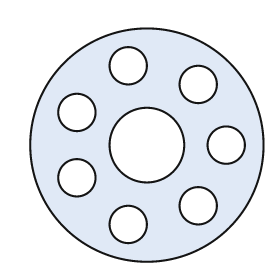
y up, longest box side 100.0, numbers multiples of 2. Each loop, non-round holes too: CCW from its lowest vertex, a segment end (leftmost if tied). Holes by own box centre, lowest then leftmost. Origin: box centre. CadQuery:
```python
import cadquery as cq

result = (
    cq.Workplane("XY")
    .moveTo(0.0, 0.0)
    .circle(50.0)
    .moveTo(-8.0, -34.0)
    .circle(8.0)
    .moveTo(22.0, -26.0)
    .circle(8.0)
    .moveTo(-30.0, -14.0)
    .circle(8.0)
    .moveTo(0.0, 0.0)
    .circle(16.0)
    .moveTo(34.0, 0.0)
    .circle(8.0)
    .moveTo(-30.0, 14.0)
    .circle(8.0)
    .moveTo(22.0, 26.0)
    .circle(8.0)
    .moveTo(-8.0, 34.0)
    .circle(8.0)
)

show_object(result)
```